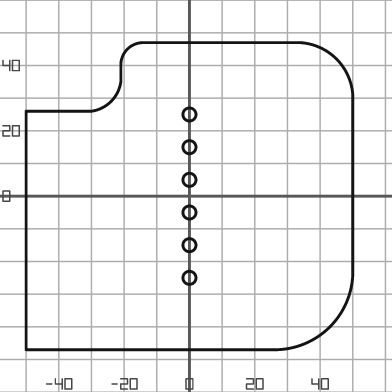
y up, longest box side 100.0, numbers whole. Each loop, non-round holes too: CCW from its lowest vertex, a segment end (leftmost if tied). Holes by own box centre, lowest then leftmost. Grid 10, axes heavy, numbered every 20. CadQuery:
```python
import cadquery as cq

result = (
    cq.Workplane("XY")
    .moveTo(-50.0, -47.0)
    .lineTo(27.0, -47.0)
    .threePointArc((43.0, -40.0), (50.0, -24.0))
    .lineTo(50.0, 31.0)
    .threePointArc((45.0, 42.0), (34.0, 47.0))
    .lineTo(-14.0, 47.0)
    .threePointArc((-19.0, 45.0), (-21.0, 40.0))
    .lineTo(-21.0, 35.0)
    .threePointArc((-24.0, 29.0), (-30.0, 26.0))
    .lineTo(-50.0, 26.0)
    .close()
    .moveTo(0.0, -25.0)
    .circle(2.0)
    .moveTo(0.0, -15.0)
    .circle(2.0)
    .moveTo(0.0, -5.0)
    .circle(2.0)
    .moveTo(0.0, 5.0)
    .circle(2.0)
    .moveTo(0.0, 15.0)
    .circle(2.0)
    .moveTo(0.0, 25.0)
    .circle(2.0)
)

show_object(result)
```